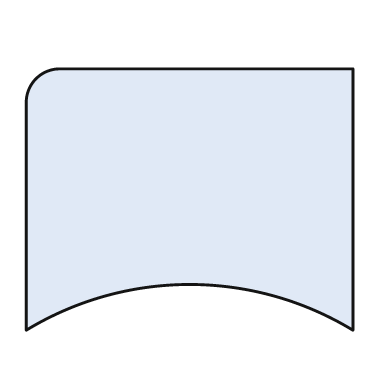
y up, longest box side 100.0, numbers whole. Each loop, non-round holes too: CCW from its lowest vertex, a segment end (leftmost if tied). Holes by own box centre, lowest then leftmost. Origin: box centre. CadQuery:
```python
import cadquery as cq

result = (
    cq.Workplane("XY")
    .moveTo(-50.0, -40.0)
    .threePointArc((0.0, -26.0), (50.0, -40.0))
    .lineTo(50.0, 40.0)
    .lineTo(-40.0, 40.0)
    .threePointArc((-47.0, 37.0), (-50.0, 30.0))
    .close()
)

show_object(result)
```